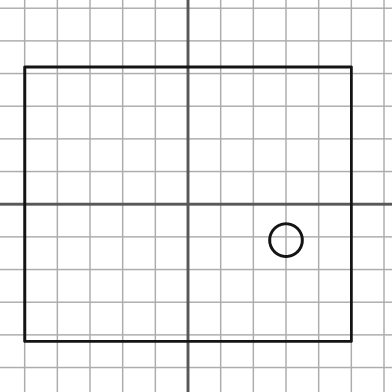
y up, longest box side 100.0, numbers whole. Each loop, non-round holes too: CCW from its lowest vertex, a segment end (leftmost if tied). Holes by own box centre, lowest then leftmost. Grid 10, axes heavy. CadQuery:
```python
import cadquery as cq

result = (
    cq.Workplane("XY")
    .moveTo(-50.0, -42.0)
    .lineTo(50.0, -42.0)
    .lineTo(50.0, 42.0)
    .lineTo(-50.0, 42.0)
    .close()
    .moveTo(30.0, -11.0)
    .circle(5.0)
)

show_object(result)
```